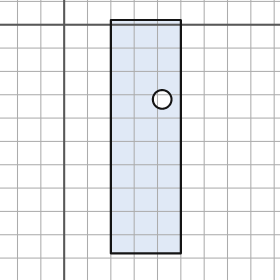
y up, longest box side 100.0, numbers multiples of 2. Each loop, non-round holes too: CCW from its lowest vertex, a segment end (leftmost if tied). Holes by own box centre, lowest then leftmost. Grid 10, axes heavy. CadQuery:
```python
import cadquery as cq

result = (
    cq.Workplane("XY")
    .moveTo(20.0, -98.0)
    .lineTo(50.0, -98.0)
    .lineTo(50.0, 2.0)
    .lineTo(20.0, 2.0)
    .close()
    .moveTo(42.0, -32.0)
    .circle(4.0)
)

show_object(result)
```